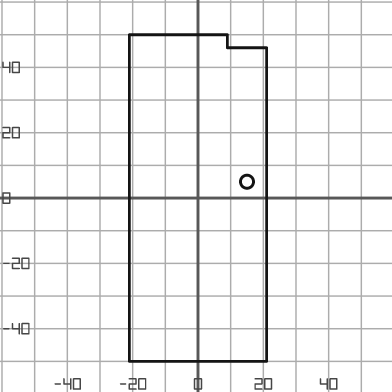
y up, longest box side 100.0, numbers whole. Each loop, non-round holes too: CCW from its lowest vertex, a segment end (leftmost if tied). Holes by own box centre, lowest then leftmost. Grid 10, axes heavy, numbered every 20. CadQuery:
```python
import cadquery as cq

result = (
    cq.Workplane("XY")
    .moveTo(-21.0, -50.0)
    .lineTo(21.0, -50.0)
    .lineTo(21.0, 46.0)
    .lineTo(9.0, 46.0)
    .lineTo(9.0, 50.0)
    .lineTo(-21.0, 50.0)
    .close()
    .moveTo(15.0, 5.0)
    .circle(2.0)
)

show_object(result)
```